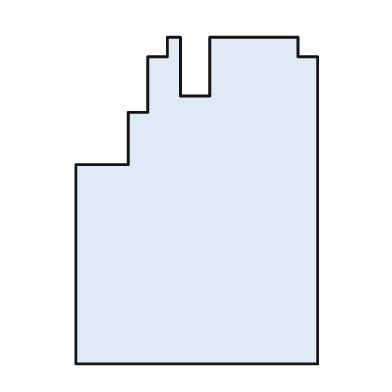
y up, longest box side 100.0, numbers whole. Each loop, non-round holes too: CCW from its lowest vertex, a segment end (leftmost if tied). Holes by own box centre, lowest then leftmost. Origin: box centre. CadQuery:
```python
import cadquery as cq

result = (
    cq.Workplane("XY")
    .moveTo(-37.0, -50.0)
    .lineTo(37.0, -50.0)
    .lineTo(37.0, 44.0)
    .lineTo(31.0, 44.0)
    .lineTo(31.0, 50.0)
    .lineTo(4.0, 50.0)
    .lineTo(4.0, 32.0)
    .lineTo(-5.0, 32.0)
    .lineTo(-5.0, 50.0)
    .lineTo(-9.0, 50.0)
    .lineTo(-9.0, 44.0)
    .lineTo(-15.0, 44.0)
    .lineTo(-15.0, 27.0)
    .lineTo(-21.0, 27.0)
    .lineTo(-21.0, 11.0)
    .lineTo(-37.0, 11.0)
    .close()
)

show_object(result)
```